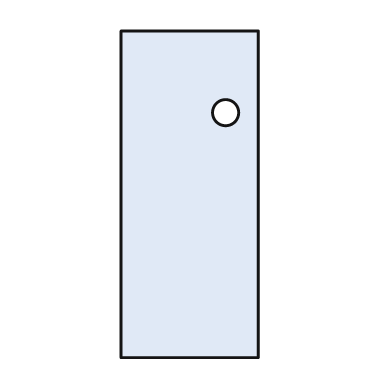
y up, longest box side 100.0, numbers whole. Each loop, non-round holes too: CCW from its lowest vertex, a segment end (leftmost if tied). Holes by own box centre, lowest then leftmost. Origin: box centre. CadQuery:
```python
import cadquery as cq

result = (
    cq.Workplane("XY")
    .moveTo(-21.0, -50.0)
    .lineTo(21.0, -50.0)
    .lineTo(21.0, 50.0)
    .lineTo(-21.0, 50.0)
    .close()
    .moveTo(11.0, 25.0)
    .circle(4.0)
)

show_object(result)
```